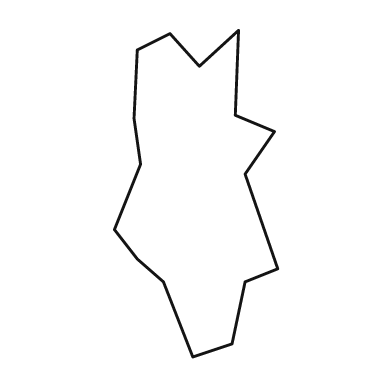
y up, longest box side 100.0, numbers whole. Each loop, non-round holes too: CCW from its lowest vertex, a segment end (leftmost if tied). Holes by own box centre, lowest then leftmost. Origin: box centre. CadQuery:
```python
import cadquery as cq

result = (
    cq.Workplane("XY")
    .moveTo(-1.0, -50.0)
    .lineTo(11.0, -46.0)
    .lineTo(15.0, -27.0)
    .lineTo(25.0, -23.0)
    .lineTo(15.0, 6.0)
    .lineTo(24.0, 19.0)
    .lineTo(12.0, 24.0)
    .lineTo(13.0, 50.0)
    .lineTo(1.0, 39.0)
    .lineTo(-8.0, 49.0)
    .lineTo(-18.0, 44.0)
    .lineTo(-19.0, 23.0)
    .lineTo(-17.0, 9.0)
    .lineTo(-25.0, -11.0)
    .lineTo(-18.0, -20.0)
    .lineTo(-10.0, -27.0)
    .close()
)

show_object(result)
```